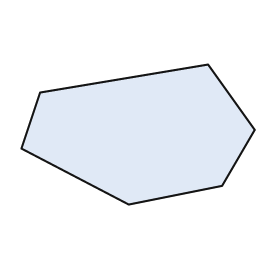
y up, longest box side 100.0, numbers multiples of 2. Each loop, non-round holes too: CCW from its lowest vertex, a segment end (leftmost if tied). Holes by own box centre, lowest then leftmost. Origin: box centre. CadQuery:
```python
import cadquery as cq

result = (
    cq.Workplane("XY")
    .moveTo(-4.0, -30.0)
    .lineTo(36.0, -22.0)
    .lineTo(50.0, 2.0)
    .lineTo(30.0, 30.0)
    .lineTo(-42.0, 18.0)
    .lineTo(-50.0, -6.0)
    .close()
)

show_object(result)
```